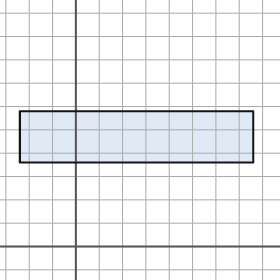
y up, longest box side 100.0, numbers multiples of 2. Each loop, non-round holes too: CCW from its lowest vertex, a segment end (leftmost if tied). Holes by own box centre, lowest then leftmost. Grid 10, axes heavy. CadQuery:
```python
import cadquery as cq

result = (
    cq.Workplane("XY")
    .moveTo(-24.0, 36.0)
    .lineTo(76.0, 36.0)
    .lineTo(76.0, 58.0)
    .lineTo(-24.0, 58.0)
    .close()
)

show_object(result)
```